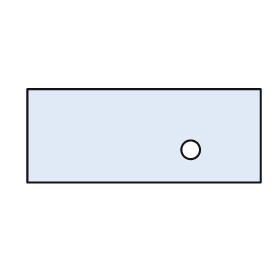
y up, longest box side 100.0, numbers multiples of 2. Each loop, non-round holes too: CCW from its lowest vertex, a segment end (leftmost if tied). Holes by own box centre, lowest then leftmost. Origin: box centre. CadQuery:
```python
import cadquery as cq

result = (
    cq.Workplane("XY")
    .moveTo(-50.0, -20.0)
    .lineTo(50.0, -20.0)
    .lineTo(50.0, 20.0)
    .lineTo(-50.0, 20.0)
    .close()
    .moveTo(20.0, -6.0)
    .circle(4.0)
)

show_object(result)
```